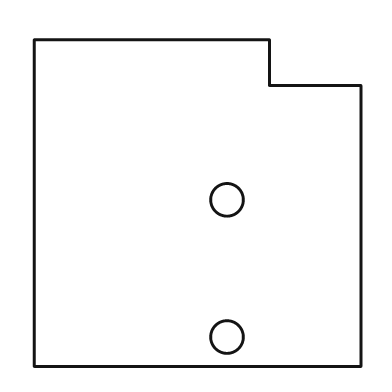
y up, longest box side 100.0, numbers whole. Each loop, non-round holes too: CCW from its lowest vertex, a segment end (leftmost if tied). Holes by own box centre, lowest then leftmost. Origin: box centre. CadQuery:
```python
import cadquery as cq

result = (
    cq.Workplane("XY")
    .moveTo(-50.0, -50.0)
    .lineTo(50.0, -50.0)
    .lineTo(50.0, 36.0)
    .lineTo(22.0, 36.0)
    .lineTo(22.0, 50.0)
    .lineTo(-50.0, 50.0)
    .close()
    .moveTo(9.0, -41.0)
    .circle(5.0)
    .moveTo(9.0, 1.0)
    .circle(5.0)
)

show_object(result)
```